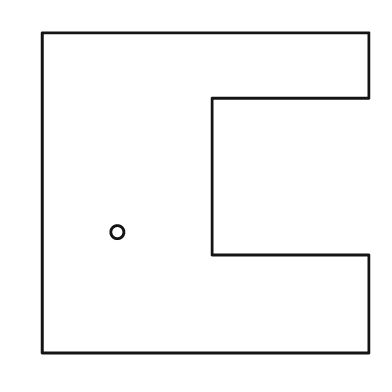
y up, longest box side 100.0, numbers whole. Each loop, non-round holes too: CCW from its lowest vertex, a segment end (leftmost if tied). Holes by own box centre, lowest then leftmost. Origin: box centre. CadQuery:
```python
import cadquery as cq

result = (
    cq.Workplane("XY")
    .moveTo(-50.0, -49.0)
    .lineTo(50.0, -49.0)
    .lineTo(50.0, -19.0)
    .lineTo(2.0, -19.0)
    .lineTo(2.0, 29.0)
    .lineTo(50.0, 29.0)
    .lineTo(50.0, 49.0)
    .lineTo(-50.0, 49.0)
    .close()
    .moveTo(-27.0, -12.0)
    .circle(2.0)
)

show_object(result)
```